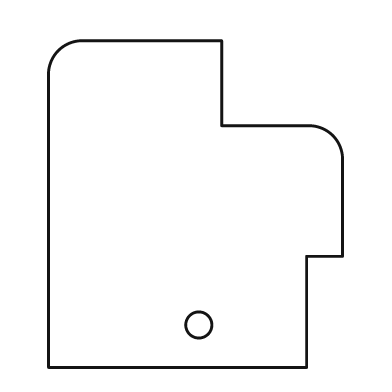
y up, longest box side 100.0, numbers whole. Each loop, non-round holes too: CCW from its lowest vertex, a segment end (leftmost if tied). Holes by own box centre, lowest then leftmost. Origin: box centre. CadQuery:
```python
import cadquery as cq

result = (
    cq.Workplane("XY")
    .moveTo(-45.0, -50.0)
    .lineTo(34.0, -50.0)
    .lineTo(34.0, -16.0)
    .lineTo(45.0, -16.0)
    .lineTo(45.0, 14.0)
    .threePointArc((42.0, 21.0), (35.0, 24.0))
    .lineTo(8.0, 24.0)
    .lineTo(8.0, 50.0)
    .lineTo(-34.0, 50.0)
    .threePointArc((-42.0, 47.0), (-45.0, 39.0))
    .close()
    .moveTo(1.0, -37.0)
    .circle(4.0)
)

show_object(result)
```